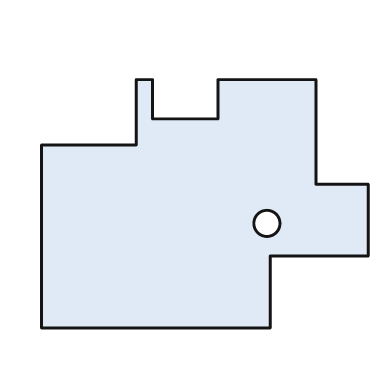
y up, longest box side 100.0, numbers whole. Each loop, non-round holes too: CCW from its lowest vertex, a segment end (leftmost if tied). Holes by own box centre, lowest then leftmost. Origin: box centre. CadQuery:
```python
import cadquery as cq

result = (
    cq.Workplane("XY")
    .moveTo(-50.0, -38.0)
    .lineTo(20.0, -38.0)
    .lineTo(20.0, -16.0)
    .lineTo(50.0, -16.0)
    .lineTo(50.0, 6.0)
    .lineTo(34.0, 6.0)
    .lineTo(34.0, 38.0)
    .lineTo(4.0, 38.0)
    .lineTo(4.0, 26.0)
    .lineTo(-16.0, 26.0)
    .lineTo(-16.0, 38.0)
    .lineTo(-21.0, 38.0)
    .lineTo(-21.0, 18.0)
    .lineTo(-50.0, 18.0)
    .close()
    .moveTo(19.0, -6.0)
    .circle(4.0)
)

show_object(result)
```